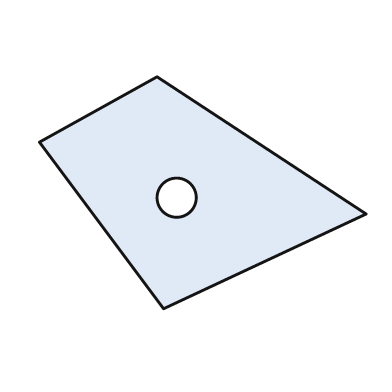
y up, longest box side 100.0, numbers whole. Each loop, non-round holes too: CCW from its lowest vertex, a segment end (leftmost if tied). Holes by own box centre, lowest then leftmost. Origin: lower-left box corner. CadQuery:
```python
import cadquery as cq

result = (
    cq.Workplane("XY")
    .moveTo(38.0, 0.0)
    .lineTo(100.0, 29.0)
    .lineTo(36.0, 71.0)
    .lineTo(0.0, 51.0)
    .close()
    .moveTo(42.0, 34.0)
    .circle(6.0)
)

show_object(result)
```